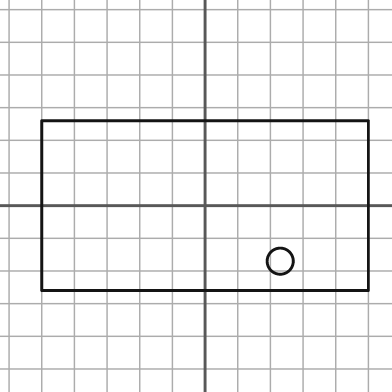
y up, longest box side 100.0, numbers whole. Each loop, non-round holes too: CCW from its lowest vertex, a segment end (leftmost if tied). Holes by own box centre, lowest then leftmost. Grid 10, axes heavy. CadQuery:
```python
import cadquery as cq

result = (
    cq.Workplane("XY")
    .moveTo(-50.0, -26.0)
    .lineTo(50.0, -26.0)
    .lineTo(50.0, 26.0)
    .lineTo(-50.0, 26.0)
    .close()
    .moveTo(23.0, -17.0)
    .circle(4.0)
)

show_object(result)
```